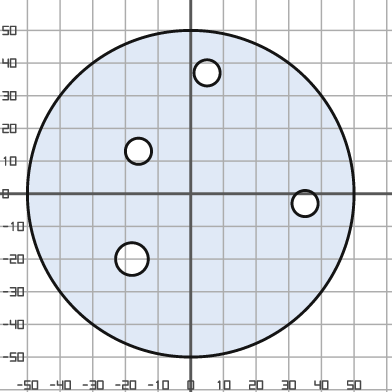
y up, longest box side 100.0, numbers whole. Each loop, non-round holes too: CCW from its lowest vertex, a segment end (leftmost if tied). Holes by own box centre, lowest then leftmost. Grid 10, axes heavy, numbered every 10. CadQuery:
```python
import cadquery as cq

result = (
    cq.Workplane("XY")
    .moveTo(0.0, 0.0)
    .circle(50.0)
    .moveTo(-18.0, -20.0)
    .circle(5.0)
    .moveTo(35.0, -3.0)
    .circle(4.0)
    .moveTo(-16.0, 13.0)
    .circle(4.0)
    .moveTo(5.0, 37.0)
    .circle(4.0)
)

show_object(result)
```